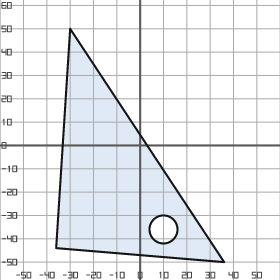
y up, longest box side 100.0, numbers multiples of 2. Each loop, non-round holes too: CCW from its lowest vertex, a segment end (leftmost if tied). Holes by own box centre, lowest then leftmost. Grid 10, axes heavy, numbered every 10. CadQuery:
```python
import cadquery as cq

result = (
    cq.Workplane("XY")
    .moveTo(36.0, -50.0)
    .lineTo(-30.0, 50.0)
    .lineTo(-36.0, -44.0)
    .close()
    .moveTo(10.0, -36.0)
    .circle(6.0)
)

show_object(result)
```